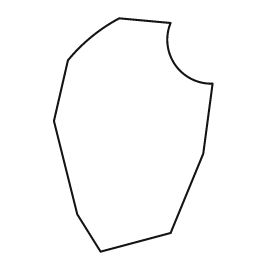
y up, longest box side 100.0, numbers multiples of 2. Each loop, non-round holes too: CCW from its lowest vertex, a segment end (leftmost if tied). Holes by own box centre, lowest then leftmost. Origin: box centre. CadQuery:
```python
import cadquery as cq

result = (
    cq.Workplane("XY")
    .moveTo(-14.0, -50.0)
    .lineTo(16.0, -42.0)
    .lineTo(30.0, -8.0)
    .lineTo(34.0, 22.0)
    .threePointArc((18.0, 30.0), (16.0, 48.0))
    .lineTo(-6.0, 50.0)
    .threePointArc((-18.0, 42.0), (-28.0, 32.0))
    .lineTo(-34.0, 6.0)
    .lineTo(-24.0, -34.0)
    .close()
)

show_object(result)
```